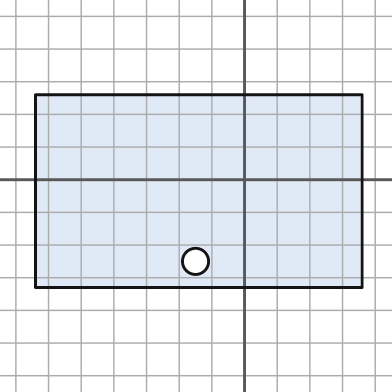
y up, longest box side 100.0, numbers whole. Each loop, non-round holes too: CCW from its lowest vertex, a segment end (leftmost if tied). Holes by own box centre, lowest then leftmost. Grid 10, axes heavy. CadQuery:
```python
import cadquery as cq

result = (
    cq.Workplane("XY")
    .moveTo(-64.0, -33.0)
    .lineTo(36.0, -33.0)
    .lineTo(36.0, 26.0)
    .lineTo(-64.0, 26.0)
    .close()
    .moveTo(-15.0, -25.0)
    .circle(4.0)
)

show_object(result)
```